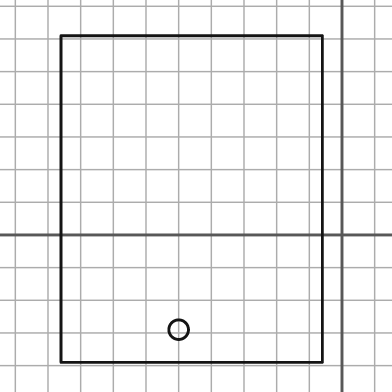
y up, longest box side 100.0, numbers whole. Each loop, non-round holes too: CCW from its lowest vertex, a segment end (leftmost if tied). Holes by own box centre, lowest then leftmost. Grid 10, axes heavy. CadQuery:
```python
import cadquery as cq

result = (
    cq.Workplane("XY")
    .moveTo(-86.0, -39.0)
    .lineTo(-6.0, -39.0)
    .lineTo(-6.0, 61.0)
    .lineTo(-86.0, 61.0)
    .close()
    .moveTo(-50.0, -29.0)
    .circle(3.0)
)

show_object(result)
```